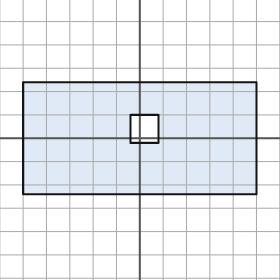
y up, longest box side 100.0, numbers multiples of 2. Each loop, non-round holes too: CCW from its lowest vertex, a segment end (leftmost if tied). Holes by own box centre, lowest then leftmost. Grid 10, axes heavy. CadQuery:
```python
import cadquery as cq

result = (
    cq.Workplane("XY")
    .moveTo(-50.0, -24.0)
    .lineTo(50.0, -24.0)
    .lineTo(50.0, 24.0)
    .lineTo(-50.0, 24.0)
    .close()
    .moveTo(-4.0, -2.0)
    .lineTo(8.0, -2.0)
    .lineTo(8.0, 10.0)
    .lineTo(-4.0, 10.0)
    .close()
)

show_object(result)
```